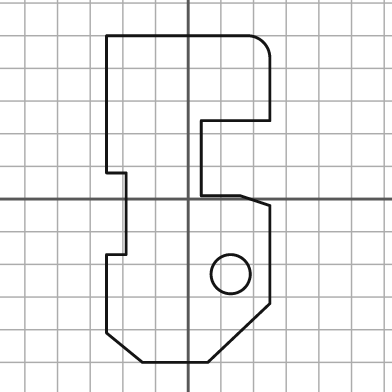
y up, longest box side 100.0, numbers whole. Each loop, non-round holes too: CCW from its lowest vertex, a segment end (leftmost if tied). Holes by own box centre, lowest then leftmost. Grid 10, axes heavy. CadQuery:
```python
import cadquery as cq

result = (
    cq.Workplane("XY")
    .moveTo(-14.0, -50.0)
    .lineTo(6.0, -50.0)
    .lineTo(25.0, -32.0)
    .lineTo(25.0, -2.0)
    .lineTo(16.0, 1.0)
    .lineTo(4.0, 1.0)
    .lineTo(4.0, 24.0)
    .lineTo(25.0, 24.0)
    .lineTo(25.0, 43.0)
    .threePointArc((23.0, 48.0), (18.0, 50.0))
    .lineTo(-25.0, 50.0)
    .lineTo(-25.0, 8.0)
    .lineTo(-19.0, 8.0)
    .lineTo(-19.0, -17.0)
    .lineTo(-25.0, -17.0)
    .lineTo(-25.0, -41.0)
    .close()
    .moveTo(13.0, -23.0)
    .circle(6.0)
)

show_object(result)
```